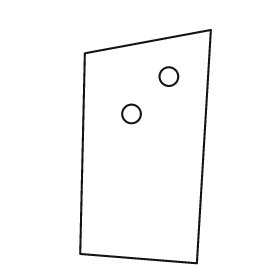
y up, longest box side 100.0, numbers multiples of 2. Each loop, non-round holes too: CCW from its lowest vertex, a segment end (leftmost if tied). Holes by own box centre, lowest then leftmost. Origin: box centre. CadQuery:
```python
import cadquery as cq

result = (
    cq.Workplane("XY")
    .moveTo(22.0, -50.0)
    .lineTo(28.0, 50.0)
    .lineTo(-26.0, 40.0)
    .lineTo(-28.0, -46.0)
    .close()
    .moveTo(-6.0, 14.0)
    .circle(4.0)
    .moveTo(10.0, 30.0)
    .circle(4.0)
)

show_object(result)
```